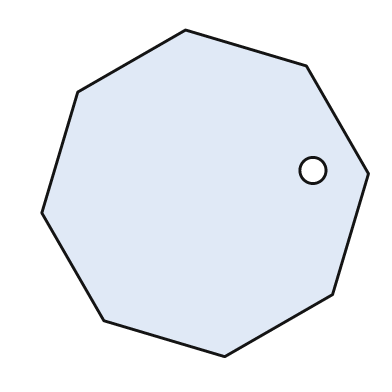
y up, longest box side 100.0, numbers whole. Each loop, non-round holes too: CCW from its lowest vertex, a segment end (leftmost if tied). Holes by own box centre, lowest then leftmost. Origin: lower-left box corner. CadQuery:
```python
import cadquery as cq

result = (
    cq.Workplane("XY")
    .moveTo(56.0, 0.0)
    .lineTo(89.0, 19.0)
    .lineTo(100.0, 56.0)
    .lineTo(81.0, 89.0)
    .lineTo(44.0, 100.0)
    .lineTo(11.0, 81.0)
    .lineTo(0.0, 44.0)
    .lineTo(19.0, 11.0)
    .close()
    .moveTo(83.0, 57.0)
    .circle(4.0)
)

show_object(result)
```